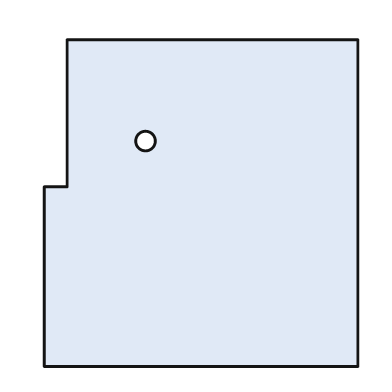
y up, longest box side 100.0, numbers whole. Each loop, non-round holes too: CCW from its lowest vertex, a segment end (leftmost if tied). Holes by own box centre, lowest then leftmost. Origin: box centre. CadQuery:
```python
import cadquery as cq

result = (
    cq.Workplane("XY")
    .moveTo(-48.0, -50.0)
    .lineTo(48.0, -50.0)
    .lineTo(48.0, 50.0)
    .lineTo(-41.0, 50.0)
    .lineTo(-41.0, 5.0)
    .lineTo(-48.0, 5.0)
    .close()
    .moveTo(-17.0, 19.0)
    .circle(3.0)
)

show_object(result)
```